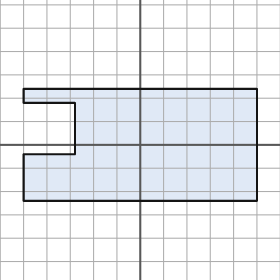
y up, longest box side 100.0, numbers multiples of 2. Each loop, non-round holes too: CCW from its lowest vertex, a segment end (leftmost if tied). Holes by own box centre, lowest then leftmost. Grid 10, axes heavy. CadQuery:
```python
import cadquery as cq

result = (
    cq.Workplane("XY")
    .moveTo(-50.0, -24.0)
    .lineTo(50.0, -24.0)
    .lineTo(50.0, 24.0)
    .lineTo(-50.0, 24.0)
    .lineTo(-50.0, 18.0)
    .lineTo(-28.0, 18.0)
    .lineTo(-28.0, -4.0)
    .lineTo(-50.0, -4.0)
    .close()
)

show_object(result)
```